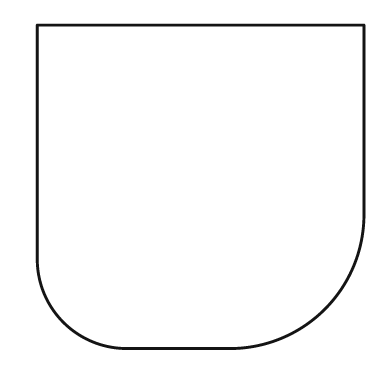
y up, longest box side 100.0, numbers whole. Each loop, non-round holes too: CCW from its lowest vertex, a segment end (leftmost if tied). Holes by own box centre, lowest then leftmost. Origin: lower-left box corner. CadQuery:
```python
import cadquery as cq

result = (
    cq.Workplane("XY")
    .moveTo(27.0, 0.0)
    .lineTo(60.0, 0.0)
    .threePointArc((88.0, 12.0), (100.0, 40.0))
    .lineTo(100.0, 99.0)
    .lineTo(0.0, 99.0)
    .lineTo(0.0, 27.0)
    .threePointArc((8.0, 8.0), (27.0, 0.0))
    .close()
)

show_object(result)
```